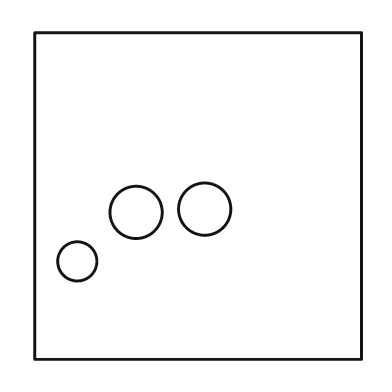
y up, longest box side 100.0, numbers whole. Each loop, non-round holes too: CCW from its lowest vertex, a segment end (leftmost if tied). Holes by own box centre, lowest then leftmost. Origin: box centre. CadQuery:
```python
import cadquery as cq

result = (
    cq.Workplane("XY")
    .moveTo(-50.0, -50.0)
    .lineTo(50.0, -50.0)
    .lineTo(50.0, 50.0)
    .lineTo(-50.0, 50.0)
    .close()
    .moveTo(-37.0, -20.0)
    .circle(6.0)
    .moveTo(-19.0, -5.0)
    .circle(8.0)
    .moveTo(2.0, -4.0)
    .circle(8.0)
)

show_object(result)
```